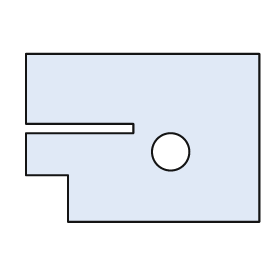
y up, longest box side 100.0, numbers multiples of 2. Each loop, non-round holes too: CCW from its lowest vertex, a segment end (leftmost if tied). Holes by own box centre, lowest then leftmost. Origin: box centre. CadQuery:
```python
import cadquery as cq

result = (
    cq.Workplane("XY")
    .moveTo(-32.0, -36.0)
    .lineTo(50.0, -36.0)
    .lineTo(50.0, 36.0)
    .lineTo(-50.0, 36.0)
    .lineTo(-50.0, 6.0)
    .lineTo(-4.0, 6.0)
    .lineTo(-4.0, 2.0)
    .lineTo(-50.0, 2.0)
    .lineTo(-50.0, -16.0)
    .lineTo(-32.0, -16.0)
    .close()
    .moveTo(12.0, -6.0)
    .circle(8.0)
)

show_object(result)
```